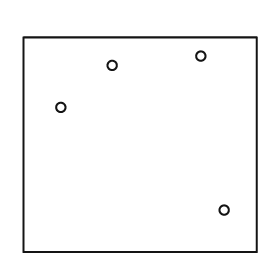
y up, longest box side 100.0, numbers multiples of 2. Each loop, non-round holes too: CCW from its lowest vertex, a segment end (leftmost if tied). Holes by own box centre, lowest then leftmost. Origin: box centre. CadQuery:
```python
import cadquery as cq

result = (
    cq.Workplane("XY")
    .moveTo(-50.0, -46.0)
    .lineTo(50.0, -46.0)
    .lineTo(50.0, 46.0)
    .lineTo(-50.0, 46.0)
    .close()
    .moveTo(36.0, -28.0)
    .circle(2.0)
    .moveTo(-34.0, 16.0)
    .circle(2.0)
    .moveTo(-12.0, 34.0)
    .circle(2.0)
    .moveTo(26.0, 38.0)
    .circle(2.0)
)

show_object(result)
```